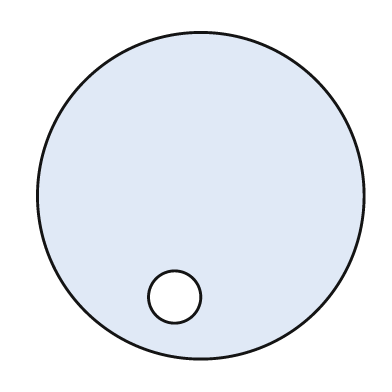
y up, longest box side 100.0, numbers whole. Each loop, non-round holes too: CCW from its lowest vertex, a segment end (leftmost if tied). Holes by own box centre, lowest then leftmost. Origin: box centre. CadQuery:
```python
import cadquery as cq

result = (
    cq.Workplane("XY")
    .moveTo(0.0, 0.0)
    .circle(50.0)
    .moveTo(-8.0, -31.0)
    .circle(8.0)
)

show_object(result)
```